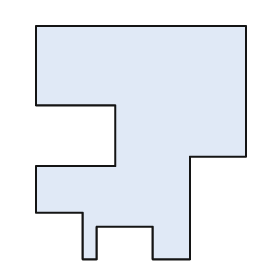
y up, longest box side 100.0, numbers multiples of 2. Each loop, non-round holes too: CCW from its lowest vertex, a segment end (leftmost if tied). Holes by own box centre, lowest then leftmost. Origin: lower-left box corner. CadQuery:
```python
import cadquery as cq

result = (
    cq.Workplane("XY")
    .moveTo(20.0, 0.0)
    .lineTo(26.0, 0.0)
    .lineTo(26.0, 14.0)
    .lineTo(50.0, 14.0)
    .lineTo(50.0, 0.0)
    .lineTo(66.0, 0.0)
    .lineTo(66.0, 44.0)
    .lineTo(90.0, 44.0)
    .lineTo(90.0, 100.0)
    .lineTo(0.0, 100.0)
    .lineTo(0.0, 66.0)
    .lineTo(34.0, 66.0)
    .lineTo(34.0, 40.0)
    .lineTo(0.0, 40.0)
    .lineTo(0.0, 20.0)
    .lineTo(20.0, 20.0)
    .close()
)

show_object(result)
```